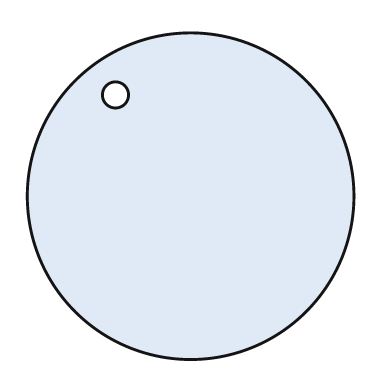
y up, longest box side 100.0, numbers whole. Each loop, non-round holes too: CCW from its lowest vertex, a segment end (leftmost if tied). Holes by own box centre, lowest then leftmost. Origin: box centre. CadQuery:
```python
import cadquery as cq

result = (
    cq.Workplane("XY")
    .moveTo(0.0, 0.0)
    .circle(50.0)
    .moveTo(-23.0, 31.0)
    .circle(4.0)
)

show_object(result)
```